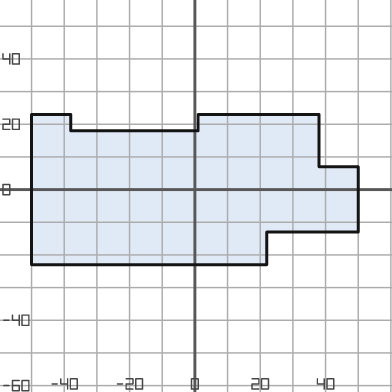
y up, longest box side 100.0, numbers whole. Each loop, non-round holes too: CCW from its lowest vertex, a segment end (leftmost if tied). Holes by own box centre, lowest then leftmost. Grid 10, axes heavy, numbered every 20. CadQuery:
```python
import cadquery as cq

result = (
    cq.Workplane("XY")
    .moveTo(-50.0, -23.0)
    .lineTo(22.0, -23.0)
    .lineTo(22.0, -13.0)
    .lineTo(50.0, -13.0)
    .lineTo(50.0, 7.0)
    .lineTo(38.0, 7.0)
    .lineTo(38.0, 23.0)
    .lineTo(1.0, 23.0)
    .lineTo(1.0, 18.0)
    .lineTo(-38.0, 18.0)
    .lineTo(-38.0, 23.0)
    .lineTo(-50.0, 23.0)
    .close()
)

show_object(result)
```